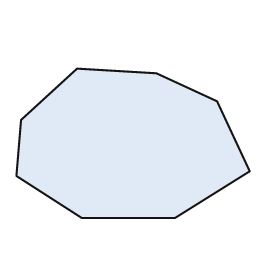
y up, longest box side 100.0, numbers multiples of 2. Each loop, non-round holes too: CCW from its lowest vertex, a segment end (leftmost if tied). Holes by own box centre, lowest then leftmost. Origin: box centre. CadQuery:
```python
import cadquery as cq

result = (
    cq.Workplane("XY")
    .moveTo(-22.0, -32.0)
    .lineTo(18.0, -32.0)
    .lineTo(50.0, -12.0)
    .lineTo(36.0, 18.0)
    .lineTo(10.0, 30.0)
    .lineTo(-24.0, 32.0)
    .lineTo(-48.0, 10.0)
    .lineTo(-50.0, -14.0)
    .close()
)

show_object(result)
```